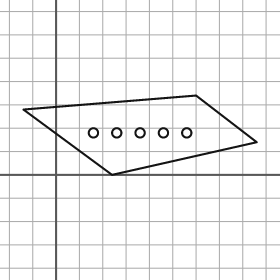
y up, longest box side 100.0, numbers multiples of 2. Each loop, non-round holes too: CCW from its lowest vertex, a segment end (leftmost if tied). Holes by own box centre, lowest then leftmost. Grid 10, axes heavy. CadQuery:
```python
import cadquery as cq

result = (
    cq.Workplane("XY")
    .moveTo(24.0, 0.0)
    .lineTo(86.0, 14.0)
    .lineTo(60.0, 34.0)
    .lineTo(-14.0, 28.0)
    .close()
    .moveTo(16.0, 18.0)
    .circle(2.0)
    .moveTo(26.0, 18.0)
    .circle(2.0)
    .moveTo(36.0, 18.0)
    .circle(2.0)
    .moveTo(46.0, 18.0)
    .circle(2.0)
    .moveTo(56.0, 18.0)
    .circle(2.0)
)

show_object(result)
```